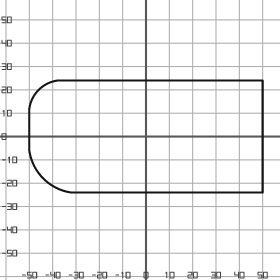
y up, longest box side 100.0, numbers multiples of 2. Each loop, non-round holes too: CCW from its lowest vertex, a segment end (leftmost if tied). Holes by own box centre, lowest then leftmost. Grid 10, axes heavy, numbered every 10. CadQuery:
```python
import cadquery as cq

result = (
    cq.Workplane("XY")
    .moveTo(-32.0, -24.0)
    .lineTo(50.0, -24.0)
    .lineTo(50.0, 24.0)
    .lineTo(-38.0, 24.0)
    .threePointArc((-46.0, 20.0), (-50.0, 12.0))
    .lineTo(-50.0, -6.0)
    .threePointArc((-44.0, -18.0), (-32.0, -24.0))
    .close()
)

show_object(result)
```